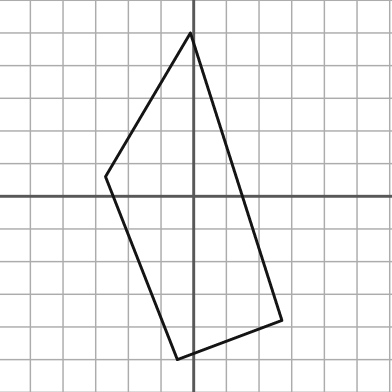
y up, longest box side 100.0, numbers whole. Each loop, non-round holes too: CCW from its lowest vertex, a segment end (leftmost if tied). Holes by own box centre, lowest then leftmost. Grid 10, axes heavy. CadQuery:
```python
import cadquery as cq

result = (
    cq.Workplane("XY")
    .moveTo(-5.0, -50.0)
    .lineTo(27.0, -38.0)
    .lineTo(-1.0, 50.0)
    .lineTo(-27.0, 6.0)
    .close()
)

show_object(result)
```